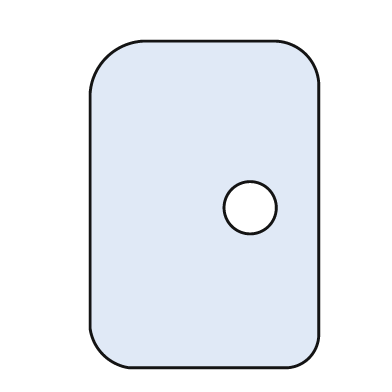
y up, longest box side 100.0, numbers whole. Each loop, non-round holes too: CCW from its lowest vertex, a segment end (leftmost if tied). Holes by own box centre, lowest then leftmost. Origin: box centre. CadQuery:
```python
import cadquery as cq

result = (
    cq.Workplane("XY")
    .moveTo(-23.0, -50.0)
    .lineTo(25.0, -50.0)
    .threePointArc((32.0, -47.0), (35.0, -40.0))
    .lineTo(35.0, 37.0)
    .threePointArc((31.0, 46.0), (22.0, 50.0))
    .lineTo(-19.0, 50.0)
    .threePointArc((-30.0, 45.0), (-35.0, 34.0))
    .lineTo(-35.0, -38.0)
    .threePointArc((-31.0, -46.0), (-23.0, -50.0))
    .close()
    .moveTo(14.0, -1.0)
    .circle(8.0)
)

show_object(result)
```